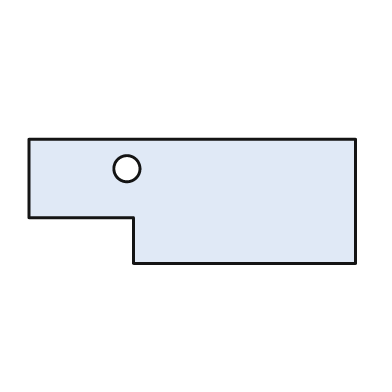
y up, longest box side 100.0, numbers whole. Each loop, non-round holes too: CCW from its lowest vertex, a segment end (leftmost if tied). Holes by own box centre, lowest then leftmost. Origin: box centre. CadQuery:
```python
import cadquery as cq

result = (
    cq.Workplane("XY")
    .moveTo(-18.0, -19.0)
    .lineTo(50.0, -19.0)
    .lineTo(50.0, 19.0)
    .lineTo(-50.0, 19.0)
    .lineTo(-50.0, -5.0)
    .lineTo(-18.0, -5.0)
    .close()
    .moveTo(-20.0, 10.0)
    .circle(4.0)
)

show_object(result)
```